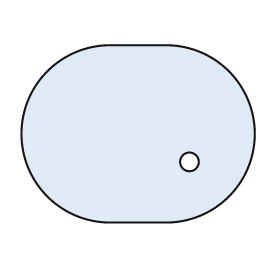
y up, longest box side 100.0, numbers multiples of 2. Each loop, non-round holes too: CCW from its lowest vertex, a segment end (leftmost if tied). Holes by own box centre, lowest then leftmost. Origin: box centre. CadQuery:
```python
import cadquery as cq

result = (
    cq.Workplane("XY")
    .moveTo(-12.0, -38.0)
    .lineTo(12.0, -38.0)
    .threePointArc((50.0, 0.0), (12.0, 38.0))
    .lineTo(-12.0, 38.0)
    .threePointArc((-50.0, 0.0), (-12.0, -38.0))
    .close()
    .moveTo(22.0, -12.0)
    .circle(4.0)
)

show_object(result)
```